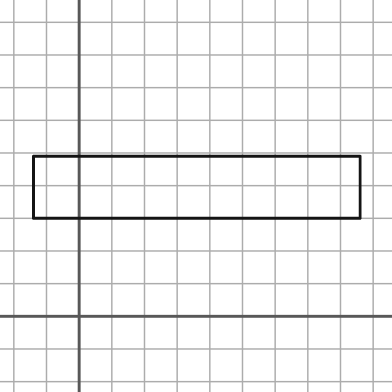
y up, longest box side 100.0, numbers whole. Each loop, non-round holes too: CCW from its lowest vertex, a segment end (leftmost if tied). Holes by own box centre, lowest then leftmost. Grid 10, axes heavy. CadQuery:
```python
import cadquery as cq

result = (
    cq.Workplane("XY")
    .moveTo(-14.0, 30.0)
    .lineTo(86.0, 30.0)
    .lineTo(86.0, 49.0)
    .lineTo(-14.0, 49.0)
    .close()
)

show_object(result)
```